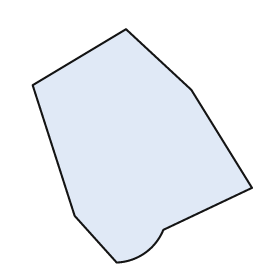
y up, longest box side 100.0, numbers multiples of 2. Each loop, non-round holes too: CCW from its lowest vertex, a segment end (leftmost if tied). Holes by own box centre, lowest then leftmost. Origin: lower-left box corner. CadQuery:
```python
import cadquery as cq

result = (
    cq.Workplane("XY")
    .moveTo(36.0, 0.0)
    .threePointArc((48.0, 4.0), (56.0, 14.0))
    .lineTo(94.0, 32.0)
    .lineTo(68.0, 74.0)
    .lineTo(40.0, 100.0)
    .lineTo(0.0, 76.0)
    .lineTo(18.0, 20.0)
    .close()
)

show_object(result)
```